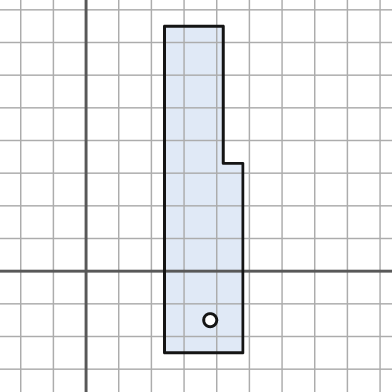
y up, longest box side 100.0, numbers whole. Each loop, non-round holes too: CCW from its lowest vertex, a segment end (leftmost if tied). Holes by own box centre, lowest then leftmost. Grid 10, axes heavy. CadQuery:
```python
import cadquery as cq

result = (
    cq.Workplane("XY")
    .moveTo(24.0, -25.0)
    .lineTo(48.0, -25.0)
    .lineTo(48.0, 33.0)
    .lineTo(42.0, 33.0)
    .lineTo(42.0, 75.0)
    .lineTo(24.0, 75.0)
    .close()
    .moveTo(38.0, -15.0)
    .circle(2.0)
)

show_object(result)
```